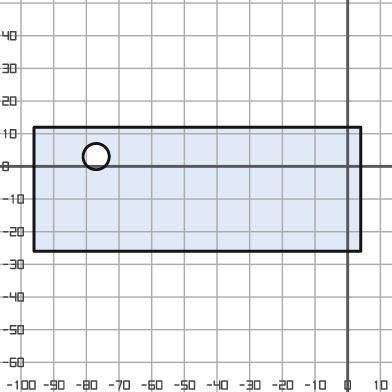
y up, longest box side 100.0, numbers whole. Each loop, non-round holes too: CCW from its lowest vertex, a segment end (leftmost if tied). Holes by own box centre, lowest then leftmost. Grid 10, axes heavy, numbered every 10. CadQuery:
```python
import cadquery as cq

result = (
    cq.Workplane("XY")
    .moveTo(-96.0, -26.0)
    .lineTo(4.0, -26.0)
    .lineTo(4.0, 12.0)
    .lineTo(-96.0, 12.0)
    .close()
    .moveTo(-77.0, 3.0)
    .circle(4.0)
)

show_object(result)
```